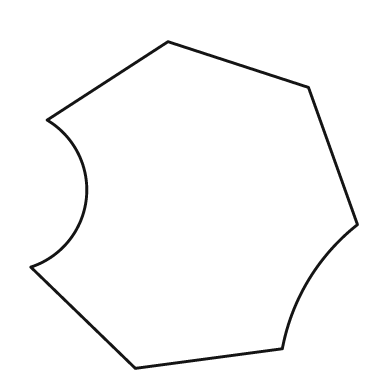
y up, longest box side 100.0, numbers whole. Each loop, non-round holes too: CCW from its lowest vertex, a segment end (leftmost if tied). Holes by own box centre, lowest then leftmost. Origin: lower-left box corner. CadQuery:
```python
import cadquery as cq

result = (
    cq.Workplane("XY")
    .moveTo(32.0, 0.0)
    .lineTo(77.0, 6.0)
    .threePointArc((85.0, 27.0), (100.0, 44.0))
    .lineTo(85.0, 86.0)
    .lineTo(42.0, 100.0)
    .lineTo(5.0, 76.0)
    .threePointArc((17.0, 52.0), (0.0, 31.0))
    .close()
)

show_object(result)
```